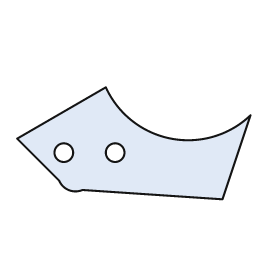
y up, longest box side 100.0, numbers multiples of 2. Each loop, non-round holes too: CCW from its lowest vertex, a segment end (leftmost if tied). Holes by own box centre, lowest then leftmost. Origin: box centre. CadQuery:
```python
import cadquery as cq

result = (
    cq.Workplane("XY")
    .moveTo(38.0, -24.0)
    .lineTo(50.0, 12.0)
    .threePointArc((16.0, 2.0), (-12.0, 24.0))
    .lineTo(-50.0, 2.0)
    .lineTo(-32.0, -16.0)
    .threePointArc((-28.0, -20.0), (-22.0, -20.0))
    .close()
    .moveTo(-30.0, -4.0)
    .circle(4.0)
    .moveTo(-8.0, -4.0)
    .circle(4.0)
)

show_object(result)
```